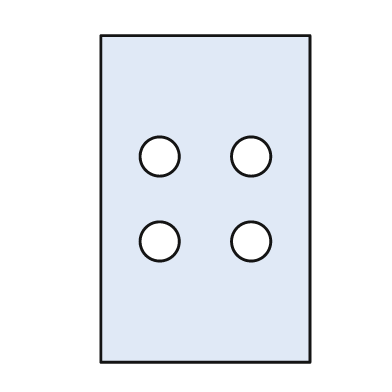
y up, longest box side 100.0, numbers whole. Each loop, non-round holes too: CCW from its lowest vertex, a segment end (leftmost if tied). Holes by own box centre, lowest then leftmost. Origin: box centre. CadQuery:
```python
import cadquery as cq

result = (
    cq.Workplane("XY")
    .moveTo(-32.0, -50.0)
    .lineTo(32.0, -50.0)
    .lineTo(32.0, 50.0)
    .lineTo(-32.0, 50.0)
    .close()
    .moveTo(-14.0, -13.0)
    .circle(6.0)
    .moveTo(14.0, -13.0)
    .circle(6.0)
    .moveTo(-14.0, 13.0)
    .circle(6.0)
    .moveTo(14.0, 13.0)
    .circle(6.0)
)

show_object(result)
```